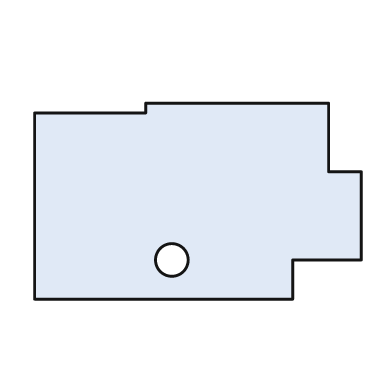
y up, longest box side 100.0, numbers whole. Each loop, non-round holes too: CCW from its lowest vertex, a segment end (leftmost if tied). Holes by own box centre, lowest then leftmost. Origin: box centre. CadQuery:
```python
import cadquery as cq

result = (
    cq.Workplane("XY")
    .moveTo(-50.0, -30.0)
    .lineTo(29.0, -30.0)
    .lineTo(29.0, -18.0)
    .lineTo(50.0, -18.0)
    .lineTo(50.0, 9.0)
    .lineTo(40.0, 9.0)
    .lineTo(40.0, 30.0)
    .lineTo(-16.0, 30.0)
    .lineTo(-16.0, 27.0)
    .lineTo(-50.0, 27.0)
    .close()
    .moveTo(-8.0, -18.0)
    .circle(5.0)
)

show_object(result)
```